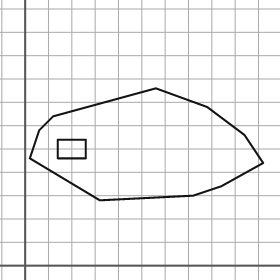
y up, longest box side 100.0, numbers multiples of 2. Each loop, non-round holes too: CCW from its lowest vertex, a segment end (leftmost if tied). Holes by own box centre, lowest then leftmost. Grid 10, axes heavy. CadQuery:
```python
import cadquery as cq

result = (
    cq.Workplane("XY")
    .moveTo(32.0, 28.0)
    .lineTo(72.0, 30.0)
    .lineTo(84.0, 34.0)
    .lineTo(102.0, 44.0)
    .lineTo(94.0, 56.0)
    .lineTo(78.0, 68.0)
    .lineTo(56.0, 76.0)
    .lineTo(12.0, 64.0)
    .lineTo(6.0, 58.0)
    .lineTo(2.0, 46.0)
    .close()
    .moveTo(14.0, 46.0)
    .lineTo(26.0, 46.0)
    .lineTo(26.0, 54.0)
    .lineTo(14.0, 54.0)
    .close()
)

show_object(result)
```